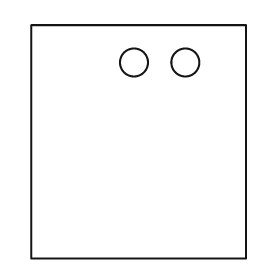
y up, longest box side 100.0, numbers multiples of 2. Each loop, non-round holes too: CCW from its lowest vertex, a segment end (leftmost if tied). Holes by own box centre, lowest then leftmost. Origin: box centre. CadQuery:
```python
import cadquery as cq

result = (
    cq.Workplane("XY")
    .moveTo(-46.0, -50.0)
    .lineTo(46.0, -50.0)
    .lineTo(46.0, 50.0)
    .lineTo(-46.0, 50.0)
    .close()
    .moveTo(-2.0, 34.0)
    .circle(6.0)
    .moveTo(20.0, 34.0)
    .circle(6.0)
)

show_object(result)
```